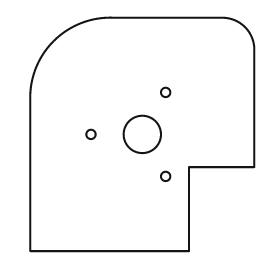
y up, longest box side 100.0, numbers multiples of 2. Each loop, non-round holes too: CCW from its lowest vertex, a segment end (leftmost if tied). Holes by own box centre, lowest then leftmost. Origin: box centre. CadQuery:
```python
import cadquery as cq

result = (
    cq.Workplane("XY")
    .moveTo(-48.0, -50.0)
    .lineTo(20.0, -50.0)
    .lineTo(20.0, -14.0)
    .lineTo(48.0, -14.0)
    .lineTo(48.0, 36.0)
    .threePointArc((44.0, 46.0), (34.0, 50.0))
    .lineTo(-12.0, 50.0)
    .threePointArc((-38.0, 40.0), (-48.0, 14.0))
    .close()
    .moveTo(10.0, -18.0)
    .circle(2.0)
    .moveTo(-22.0, 0.0)
    .circle(2.0)
    .moveTo(0.0, 0.0)
    .circle(8.0)
    .moveTo(10.0, 18.0)
    .circle(2.0)
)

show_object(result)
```